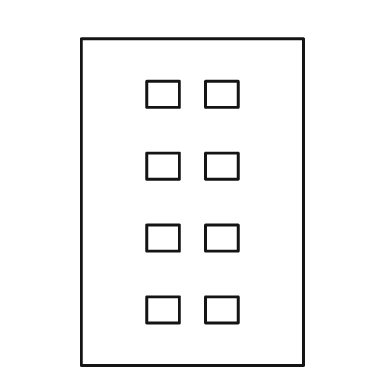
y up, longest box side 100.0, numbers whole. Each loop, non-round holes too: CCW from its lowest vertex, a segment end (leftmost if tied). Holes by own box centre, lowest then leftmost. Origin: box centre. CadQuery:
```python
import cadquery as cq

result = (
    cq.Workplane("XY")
    .moveTo(-34.0, -50.0)
    .lineTo(34.0, -50.0)
    .lineTo(34.0, 50.0)
    .lineTo(-34.0, 50.0)
    .close()
    .moveTo(-14.0, -37.0)
    .lineTo(-4.0, -37.0)
    .lineTo(-4.0, -29.0)
    .lineTo(-14.0, -29.0)
    .close()
    .moveTo(4.0, -37.0)
    .lineTo(14.0, -37.0)
    .lineTo(14.0, -29.0)
    .lineTo(4.0, -29.0)
    .close()
    .moveTo(-14.0, -15.0)
    .lineTo(-4.0, -15.0)
    .lineTo(-4.0, -7.0)
    .lineTo(-14.0, -7.0)
    .close()
    .moveTo(4.0, -15.0)
    .lineTo(14.0, -15.0)
    .lineTo(14.0, -7.0)
    .lineTo(4.0, -7.0)
    .close()
    .moveTo(-14.0, 7.0)
    .lineTo(-4.0, 7.0)
    .lineTo(-4.0, 15.0)
    .lineTo(-14.0, 15.0)
    .close()
    .moveTo(4.0, 7.0)
    .lineTo(14.0, 7.0)
    .lineTo(14.0, 15.0)
    .lineTo(4.0, 15.0)
    .close()
    .moveTo(-14.0, 29.0)
    .lineTo(-4.0, 29.0)
    .lineTo(-4.0, 37.0)
    .lineTo(-14.0, 37.0)
    .close()
    .moveTo(4.0, 29.0)
    .lineTo(14.0, 29.0)
    .lineTo(14.0, 37.0)
    .lineTo(4.0, 37.0)
    .close()
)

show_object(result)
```